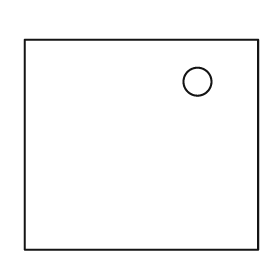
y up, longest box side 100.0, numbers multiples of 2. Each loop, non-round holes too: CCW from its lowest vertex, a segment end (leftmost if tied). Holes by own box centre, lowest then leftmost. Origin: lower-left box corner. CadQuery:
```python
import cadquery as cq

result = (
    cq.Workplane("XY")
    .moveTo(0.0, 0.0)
    .lineTo(100.0, 0.0)
    .lineTo(100.0, 90.0)
    .lineTo(0.0, 90.0)
    .close()
    .moveTo(74.0, 72.0)
    .circle(6.0)
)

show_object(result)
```